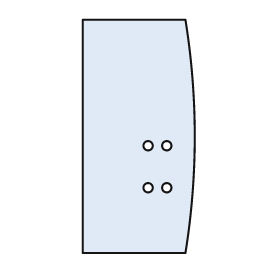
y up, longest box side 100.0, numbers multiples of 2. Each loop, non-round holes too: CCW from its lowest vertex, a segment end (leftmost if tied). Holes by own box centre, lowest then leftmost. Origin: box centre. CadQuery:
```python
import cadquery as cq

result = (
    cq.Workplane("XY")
    .moveTo(-24.0, -50.0)
    .lineTo(20.0, -50.0)
    .threePointArc((24.0, 0.0), (20.0, 50.0))
    .lineTo(-24.0, 50.0)
    .close()
    .moveTo(4.0, -22.0)
    .circle(2.0)
    .moveTo(12.0, -22.0)
    .circle(2.0)
    .moveTo(4.0, -4.0)
    .circle(2.0)
    .moveTo(12.0, -4.0)
    .circle(2.0)
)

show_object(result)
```